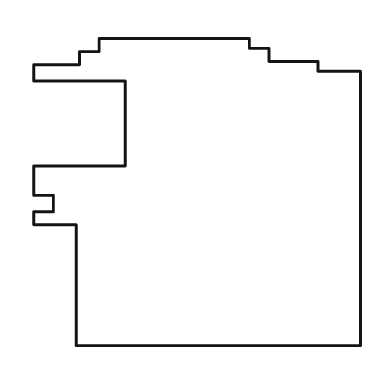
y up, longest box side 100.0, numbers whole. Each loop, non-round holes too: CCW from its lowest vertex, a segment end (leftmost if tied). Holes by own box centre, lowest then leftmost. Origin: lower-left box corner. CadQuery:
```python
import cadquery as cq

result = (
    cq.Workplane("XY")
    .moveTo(13.0, 0.0)
    .lineTo(100.0, 0.0)
    .lineTo(100.0, 84.0)
    .lineTo(87.0, 84.0)
    .lineTo(87.0, 87.0)
    .lineTo(72.0, 87.0)
    .lineTo(72.0, 91.0)
    .lineTo(66.0, 91.0)
    .lineTo(66.0, 94.0)
    .lineTo(20.0, 94.0)
    .lineTo(20.0, 90.0)
    .lineTo(14.0, 90.0)
    .lineTo(14.0, 86.0)
    .lineTo(0.0, 86.0)
    .lineTo(0.0, 81.0)
    .lineTo(28.0, 81.0)
    .lineTo(28.0, 55.0)
    .lineTo(0.0, 55.0)
    .lineTo(0.0, 46.0)
    .lineTo(6.0, 46.0)
    .lineTo(6.0, 41.0)
    .lineTo(0.0, 41.0)
    .lineTo(0.0, 37.0)
    .lineTo(13.0, 37.0)
    .close()
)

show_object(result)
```